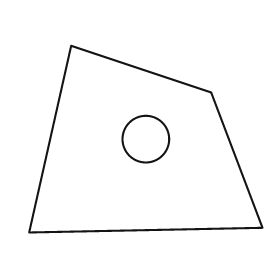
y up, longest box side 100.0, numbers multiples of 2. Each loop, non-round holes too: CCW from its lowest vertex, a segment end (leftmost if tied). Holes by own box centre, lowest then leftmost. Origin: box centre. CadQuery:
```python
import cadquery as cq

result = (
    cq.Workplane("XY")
    .moveTo(-50.0, -40.0)
    .lineTo(50.0, -38.0)
    .lineTo(28.0, 20.0)
    .lineTo(-32.0, 40.0)
    .close()
    .moveTo(0.0, 0.0)
    .circle(10.0)
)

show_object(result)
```